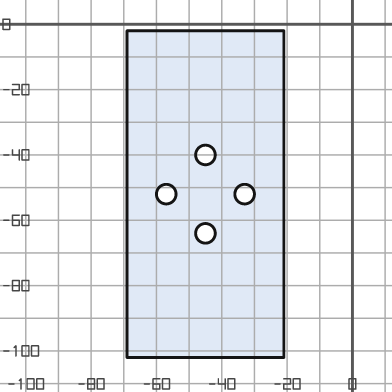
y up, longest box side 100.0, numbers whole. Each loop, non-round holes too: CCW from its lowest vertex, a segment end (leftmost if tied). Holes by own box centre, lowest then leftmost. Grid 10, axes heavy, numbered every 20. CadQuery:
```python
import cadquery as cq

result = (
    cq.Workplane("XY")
    .moveTo(-69.0, -102.0)
    .lineTo(-21.0, -102.0)
    .lineTo(-21.0, -2.0)
    .lineTo(-69.0, -2.0)
    .close()
    .moveTo(-45.0, -64.0)
    .circle(3.0)
    .moveTo(-57.0, -52.0)
    .circle(3.0)
    .moveTo(-33.0, -52.0)
    .circle(3.0)
    .moveTo(-45.0, -40.0)
    .circle(3.0)
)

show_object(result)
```